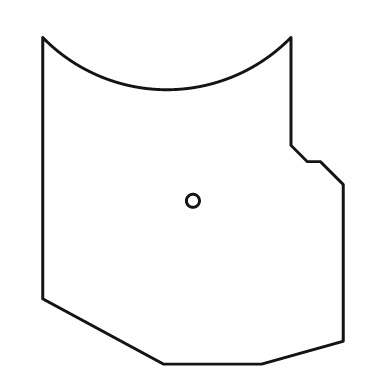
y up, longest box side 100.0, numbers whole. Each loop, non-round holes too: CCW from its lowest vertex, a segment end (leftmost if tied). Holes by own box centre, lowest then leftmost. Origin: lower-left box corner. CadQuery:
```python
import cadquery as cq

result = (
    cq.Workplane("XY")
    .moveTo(37.0, 0.0)
    .lineTo(67.0, 0.0)
    .lineTo(92.0, 7.0)
    .lineTo(92.0, 55.0)
    .lineTo(85.0, 62.0)
    .lineTo(81.0, 62.0)
    .lineTo(76.0, 67.0)
    .lineTo(76.0, 100.0)
    .threePointArc((38.0, 84.0), (0.0, 100.0))
    .lineTo(0.0, 20.0)
    .close()
    .moveTo(46.0, 50.0)
    .circle(2.0)
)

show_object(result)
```